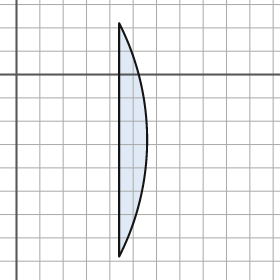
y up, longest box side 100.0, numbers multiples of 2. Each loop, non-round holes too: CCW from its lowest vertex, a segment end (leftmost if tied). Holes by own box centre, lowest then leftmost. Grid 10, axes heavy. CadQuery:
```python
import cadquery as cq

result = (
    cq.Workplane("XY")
    .moveTo(44.0, -78.0)
    .threePointArc((56.0, -28.0), (44.0, 22.0))
    .close()
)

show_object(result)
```